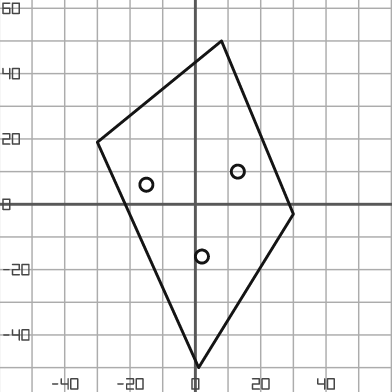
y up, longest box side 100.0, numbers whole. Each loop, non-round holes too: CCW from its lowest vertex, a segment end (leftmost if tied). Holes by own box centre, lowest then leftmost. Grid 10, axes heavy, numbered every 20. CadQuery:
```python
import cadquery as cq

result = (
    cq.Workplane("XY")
    .moveTo(1.0, -50.0)
    .lineTo(30.0, -3.0)
    .lineTo(8.0, 50.0)
    .lineTo(-30.0, 19.0)
    .close()
    .moveTo(2.0, -16.0)
    .circle(2.0)
    .moveTo(-15.0, 6.0)
    .circle(2.0)
    .moveTo(13.0, 10.0)
    .circle(2.0)
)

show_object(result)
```